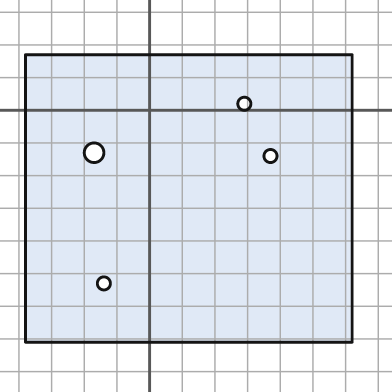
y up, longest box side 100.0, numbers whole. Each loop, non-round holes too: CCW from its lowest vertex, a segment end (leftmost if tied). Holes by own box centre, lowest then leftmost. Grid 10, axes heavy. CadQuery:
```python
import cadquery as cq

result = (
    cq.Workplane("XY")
    .moveTo(-38.0, -71.0)
    .lineTo(62.0, -71.0)
    .lineTo(62.0, 17.0)
    .lineTo(-38.0, 17.0)
    .close()
    .moveTo(-14.0, -53.0)
    .circle(2.0)
    .moveTo(37.0, -14.0)
    .circle(2.0)
    .moveTo(-17.0, -13.0)
    .circle(3.0)
    .moveTo(29.0, 2.0)
    .circle(2.0)
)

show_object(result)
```